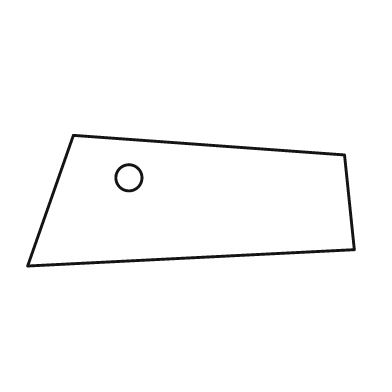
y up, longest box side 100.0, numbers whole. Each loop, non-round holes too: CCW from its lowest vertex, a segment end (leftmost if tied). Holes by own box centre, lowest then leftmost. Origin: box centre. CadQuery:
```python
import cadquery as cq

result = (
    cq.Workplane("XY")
    .moveTo(-50.0, -20.0)
    .lineTo(50.0, -15.0)
    .lineTo(47.0, 14.0)
    .lineTo(-36.0, 20.0)
    .close()
    .moveTo(-19.0, 7.0)
    .circle(4.0)
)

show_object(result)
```